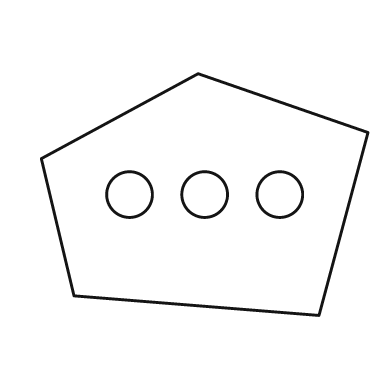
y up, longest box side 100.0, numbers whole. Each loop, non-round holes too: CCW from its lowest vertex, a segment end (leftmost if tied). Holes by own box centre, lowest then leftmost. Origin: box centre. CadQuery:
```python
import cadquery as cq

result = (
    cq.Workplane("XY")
    .moveTo(35.0, -37.0)
    .lineTo(50.0, 19.0)
    .lineTo(-2.0, 37.0)
    .lineTo(-50.0, 11.0)
    .lineTo(-40.0, -31.0)
    .close()
    .moveTo(-23.0, 0.0)
    .circle(7.0)
    .moveTo(0.0, 0.0)
    .circle(7.0)
    .moveTo(23.0, 0.0)
    .circle(7.0)
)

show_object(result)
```